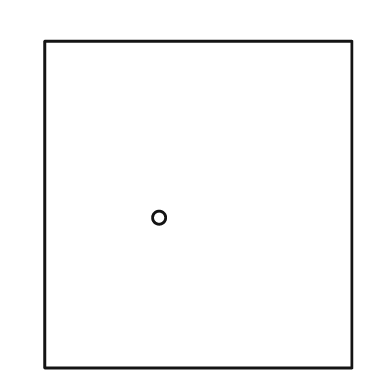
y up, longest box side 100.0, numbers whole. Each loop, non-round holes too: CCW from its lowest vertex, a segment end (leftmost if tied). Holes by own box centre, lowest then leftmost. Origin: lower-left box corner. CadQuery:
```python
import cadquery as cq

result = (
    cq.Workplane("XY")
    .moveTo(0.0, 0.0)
    .lineTo(94.0, 0.0)
    .lineTo(94.0, 100.0)
    .lineTo(0.0, 100.0)
    .close()
    .moveTo(35.0, 46.0)
    .circle(2.0)
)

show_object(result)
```